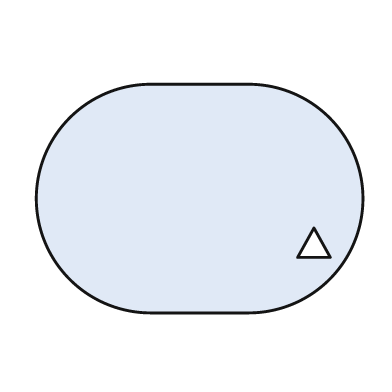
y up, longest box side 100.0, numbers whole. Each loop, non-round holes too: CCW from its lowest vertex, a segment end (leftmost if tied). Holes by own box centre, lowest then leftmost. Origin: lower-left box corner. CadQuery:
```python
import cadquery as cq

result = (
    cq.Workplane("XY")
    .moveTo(35.0, 0.0)
    .lineTo(65.0, 0.0)
    .threePointArc((100.0, 35.0), (65.0, 70.0))
    .lineTo(35.0, 70.0)
    .threePointArc((0.0, 35.0), (35.0, 0.0))
    .close()
    .moveTo(80.0, 17.0)
    .lineTo(90.0, 17.0)
    .lineTo(85.0, 26.0)
    .close()
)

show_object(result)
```